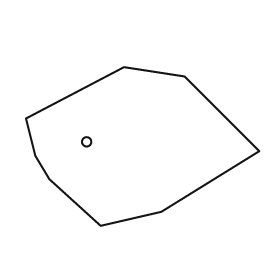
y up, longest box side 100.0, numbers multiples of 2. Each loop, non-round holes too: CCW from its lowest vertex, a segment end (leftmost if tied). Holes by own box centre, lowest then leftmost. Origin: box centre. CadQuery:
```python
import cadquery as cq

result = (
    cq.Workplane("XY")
    .moveTo(-18.0, -34.0)
    .lineTo(8.0, -28.0)
    .lineTo(50.0, -2.0)
    .lineTo(18.0, 30.0)
    .lineTo(-8.0, 34.0)
    .lineTo(-50.0, 12.0)
    .lineTo(-46.0, -4.0)
    .lineTo(-40.0, -14.0)
    .close()
    .moveTo(-24.0, 2.0)
    .circle(2.0)
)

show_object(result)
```